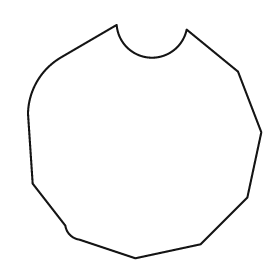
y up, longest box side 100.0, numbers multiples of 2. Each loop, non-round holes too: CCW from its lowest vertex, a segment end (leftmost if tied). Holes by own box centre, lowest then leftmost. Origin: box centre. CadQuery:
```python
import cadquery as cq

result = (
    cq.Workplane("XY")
    .moveTo(-4.0, -50.0)
    .lineTo(24.0, -44.0)
    .lineTo(44.0, -24.0)
    .lineTo(50.0, 4.0)
    .lineTo(40.0, 30.0)
    .lineTo(18.0, 48.0)
    .threePointArc((2.0, 36.0), (-12.0, 50.0))
    .lineTo(-36.0, 36.0)
    .threePointArc((-46.0, 26.0), (-50.0, 12.0))
    .lineTo(-48.0, -18.0)
    .lineTo(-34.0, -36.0)
    .threePointArc((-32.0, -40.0), (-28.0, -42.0))
    .close()
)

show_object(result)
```